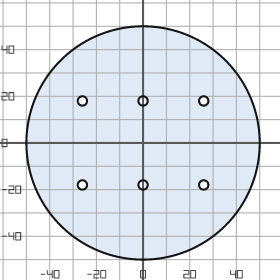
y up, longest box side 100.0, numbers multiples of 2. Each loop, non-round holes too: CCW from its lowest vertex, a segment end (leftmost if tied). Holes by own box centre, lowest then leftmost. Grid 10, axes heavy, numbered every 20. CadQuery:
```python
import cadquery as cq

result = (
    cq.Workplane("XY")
    .moveTo(0.0, 0.0)
    .circle(50.0)
    .moveTo(-26.0, -18.0)
    .circle(2.0)
    .moveTo(0.0, -18.0)
    .circle(2.0)
    .moveTo(26.0, -18.0)
    .circle(2.0)
    .moveTo(-26.0, 18.0)
    .circle(2.0)
    .moveTo(0.0, 18.0)
    .circle(2.0)
    .moveTo(26.0, 18.0)
    .circle(2.0)
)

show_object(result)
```